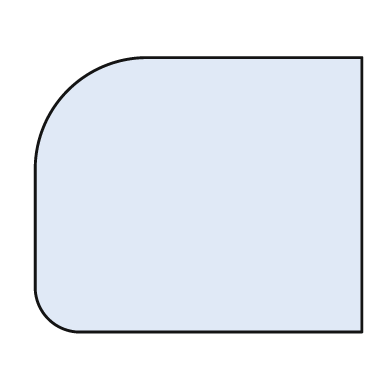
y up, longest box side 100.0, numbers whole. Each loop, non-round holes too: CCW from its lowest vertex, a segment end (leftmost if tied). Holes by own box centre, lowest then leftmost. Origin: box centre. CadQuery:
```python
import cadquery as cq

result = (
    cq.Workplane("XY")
    .moveTo(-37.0, -42.0)
    .lineTo(50.0, -42.0)
    .lineTo(50.0, 42.0)
    .lineTo(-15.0, 42.0)
    .threePointArc((-40.0, 32.0), (-50.0, 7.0))
    .lineTo(-50.0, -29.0)
    .threePointArc((-46.0, -38.0), (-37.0, -42.0))
    .close()
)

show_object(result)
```